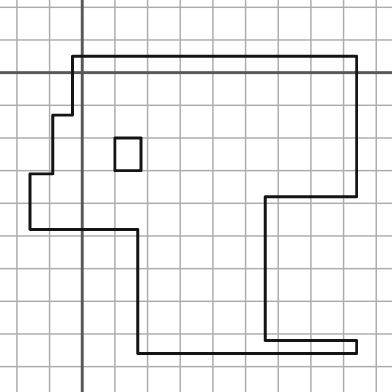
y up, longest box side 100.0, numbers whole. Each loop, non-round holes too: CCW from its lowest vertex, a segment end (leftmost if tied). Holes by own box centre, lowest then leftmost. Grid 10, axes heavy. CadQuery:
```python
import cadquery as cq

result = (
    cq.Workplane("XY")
    .moveTo(17.0, -86.0)
    .lineTo(84.0, -86.0)
    .lineTo(84.0, -82.0)
    .lineTo(56.0, -82.0)
    .lineTo(56.0, -38.0)
    .lineTo(84.0, -38.0)
    .lineTo(84.0, 5.0)
    .lineTo(-3.0, 5.0)
    .lineTo(-3.0, -13.0)
    .lineTo(-9.0, -13.0)
    .lineTo(-9.0, -31.0)
    .lineTo(-16.0, -31.0)
    .lineTo(-16.0, -48.0)
    .lineTo(17.0, -48.0)
    .close()
    .moveTo(10.0, -30.0)
    .lineTo(18.0, -30.0)
    .lineTo(18.0, -20.0)
    .lineTo(10.0, -20.0)
    .close()
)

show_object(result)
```